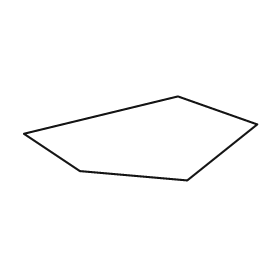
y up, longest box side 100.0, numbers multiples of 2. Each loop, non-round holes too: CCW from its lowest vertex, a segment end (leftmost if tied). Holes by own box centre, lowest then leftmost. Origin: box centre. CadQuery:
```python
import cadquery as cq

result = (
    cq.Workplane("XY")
    .moveTo(20.0, -18.0)
    .lineTo(50.0, 6.0)
    .lineTo(16.0, 18.0)
    .lineTo(-50.0, 2.0)
    .lineTo(-26.0, -14.0)
    .close()
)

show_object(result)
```